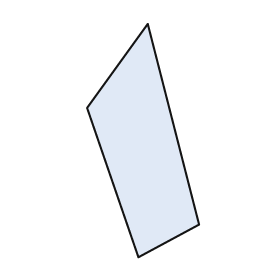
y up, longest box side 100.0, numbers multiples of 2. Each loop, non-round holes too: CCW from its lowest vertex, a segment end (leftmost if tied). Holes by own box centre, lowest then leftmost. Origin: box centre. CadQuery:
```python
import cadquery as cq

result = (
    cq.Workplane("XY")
    .moveTo(-2.0, -50.0)
    .lineTo(24.0, -36.0)
    .lineTo(2.0, 50.0)
    .lineTo(-24.0, 14.0)
    .close()
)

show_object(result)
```